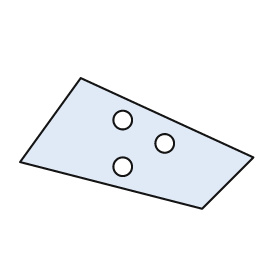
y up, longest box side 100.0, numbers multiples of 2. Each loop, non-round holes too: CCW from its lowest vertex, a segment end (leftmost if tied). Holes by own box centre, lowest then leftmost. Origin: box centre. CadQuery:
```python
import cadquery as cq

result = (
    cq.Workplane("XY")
    .moveTo(28.0, -28.0)
    .lineTo(50.0, -6.0)
    .lineTo(-24.0, 28.0)
    .lineTo(-50.0, -8.0)
    .close()
    .moveTo(-6.0, -10.0)
    .circle(4.0)
    .moveTo(12.0, 0.0)
    .circle(4.0)
    .moveTo(-6.0, 10.0)
    .circle(4.0)
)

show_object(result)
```